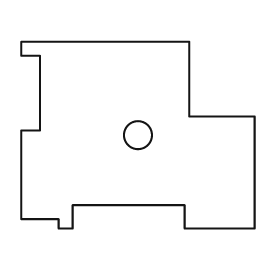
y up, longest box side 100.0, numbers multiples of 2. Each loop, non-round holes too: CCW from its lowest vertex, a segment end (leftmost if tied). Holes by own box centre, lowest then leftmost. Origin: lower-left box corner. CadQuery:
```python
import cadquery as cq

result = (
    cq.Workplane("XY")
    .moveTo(16.0, 0.0)
    .lineTo(22.0, 0.0)
    .lineTo(22.0, 10.0)
    .lineTo(70.0, 10.0)
    .lineTo(70.0, 0.0)
    .lineTo(100.0, 0.0)
    .lineTo(100.0, 48.0)
    .lineTo(72.0, 48.0)
    .lineTo(72.0, 80.0)
    .lineTo(0.0, 80.0)
    .lineTo(0.0, 74.0)
    .lineTo(8.0, 74.0)
    .lineTo(8.0, 42.0)
    .lineTo(0.0, 42.0)
    .lineTo(0.0, 4.0)
    .lineTo(16.0, 4.0)
    .close()
    .moveTo(50.0, 40.0)
    .circle(6.0)
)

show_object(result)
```